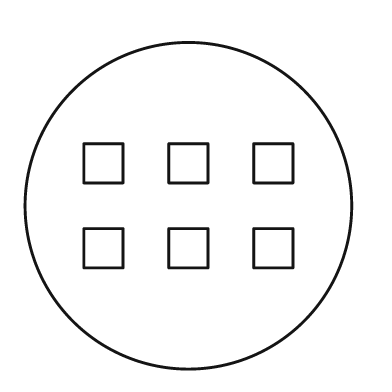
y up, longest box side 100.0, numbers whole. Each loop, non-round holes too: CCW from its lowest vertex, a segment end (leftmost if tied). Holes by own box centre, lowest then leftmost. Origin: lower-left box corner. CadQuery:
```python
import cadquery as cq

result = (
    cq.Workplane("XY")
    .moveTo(50.0, 50.0)
    .circle(50.0)
    .moveTo(18.0, 31.0)
    .lineTo(30.0, 31.0)
    .lineTo(30.0, 43.0)
    .lineTo(18.0, 43.0)
    .close()
    .moveTo(44.0, 31.0)
    .lineTo(56.0, 31.0)
    .lineTo(56.0, 43.0)
    .lineTo(44.0, 43.0)
    .close()
    .moveTo(70.0, 31.0)
    .lineTo(82.0, 31.0)
    .lineTo(82.0, 43.0)
    .lineTo(70.0, 43.0)
    .close()
    .moveTo(18.0, 57.0)
    .lineTo(30.0, 57.0)
    .lineTo(30.0, 69.0)
    .lineTo(18.0, 69.0)
    .close()
    .moveTo(44.0, 57.0)
    .lineTo(56.0, 57.0)
    .lineTo(56.0, 69.0)
    .lineTo(44.0, 69.0)
    .close()
    .moveTo(70.0, 57.0)
    .lineTo(82.0, 57.0)
    .lineTo(82.0, 69.0)
    .lineTo(70.0, 69.0)
    .close()
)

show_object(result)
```